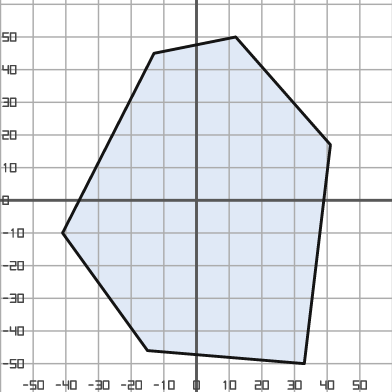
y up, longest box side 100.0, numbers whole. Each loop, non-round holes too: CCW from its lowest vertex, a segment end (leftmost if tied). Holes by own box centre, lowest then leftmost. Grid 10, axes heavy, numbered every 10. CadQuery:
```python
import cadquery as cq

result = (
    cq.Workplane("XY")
    .moveTo(33.0, -50.0)
    .lineTo(41.0, 17.0)
    .lineTo(12.0, 50.0)
    .lineTo(-13.0, 45.0)
    .lineTo(-41.0, -10.0)
    .lineTo(-15.0, -46.0)
    .close()
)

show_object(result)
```